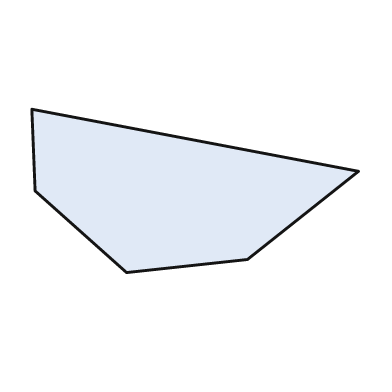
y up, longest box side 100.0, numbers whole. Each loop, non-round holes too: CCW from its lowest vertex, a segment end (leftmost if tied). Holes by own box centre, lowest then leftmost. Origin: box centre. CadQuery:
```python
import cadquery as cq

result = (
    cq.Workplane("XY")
    .moveTo(-21.0, -25.0)
    .lineTo(16.0, -21.0)
    .lineTo(50.0, 6.0)
    .lineTo(-50.0, 25.0)
    .lineTo(-49.0, 0.0)
    .close()
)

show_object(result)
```